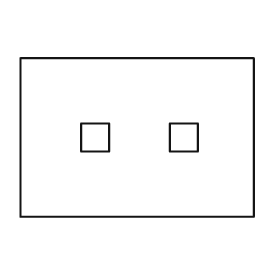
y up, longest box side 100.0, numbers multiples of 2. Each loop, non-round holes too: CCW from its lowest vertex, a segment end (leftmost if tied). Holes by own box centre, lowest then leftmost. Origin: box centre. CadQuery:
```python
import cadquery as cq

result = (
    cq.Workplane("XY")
    .moveTo(-50.0, -34.0)
    .lineTo(50.0, -34.0)
    .lineTo(50.0, 34.0)
    .lineTo(-50.0, 34.0)
    .close()
    .moveTo(-24.0, -6.0)
    .lineTo(-12.0, -6.0)
    .lineTo(-12.0, 6.0)
    .lineTo(-24.0, 6.0)
    .close()
    .moveTo(14.0, -6.0)
    .lineTo(26.0, -6.0)
    .lineTo(26.0, 6.0)
    .lineTo(14.0, 6.0)
    .close()
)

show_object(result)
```